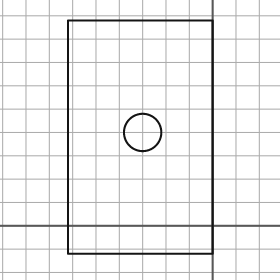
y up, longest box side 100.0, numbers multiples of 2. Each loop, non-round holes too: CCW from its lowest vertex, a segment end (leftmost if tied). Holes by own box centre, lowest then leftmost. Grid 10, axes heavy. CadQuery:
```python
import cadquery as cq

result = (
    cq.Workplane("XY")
    .moveTo(-62.0, -12.0)
    .lineTo(0.0, -12.0)
    .lineTo(0.0, 88.0)
    .lineTo(-62.0, 88.0)
    .close()
    .moveTo(-30.0, 40.0)
    .circle(8.0)
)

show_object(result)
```